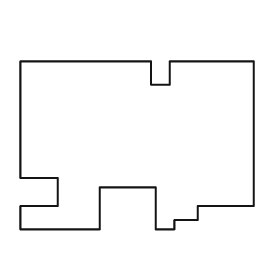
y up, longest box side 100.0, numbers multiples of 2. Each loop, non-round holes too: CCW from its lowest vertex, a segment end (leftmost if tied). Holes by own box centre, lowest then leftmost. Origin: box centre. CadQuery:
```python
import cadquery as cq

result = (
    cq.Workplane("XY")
    .moveTo(-50.0, -36.0)
    .lineTo(-16.0, -36.0)
    .lineTo(-16.0, -18.0)
    .lineTo(8.0, -18.0)
    .lineTo(8.0, -36.0)
    .lineTo(16.0, -36.0)
    .lineTo(16.0, -32.0)
    .lineTo(26.0, -32.0)
    .lineTo(26.0, -26.0)
    .lineTo(50.0, -26.0)
    .lineTo(50.0, 36.0)
    .lineTo(14.0, 36.0)
    .lineTo(14.0, 26.0)
    .lineTo(6.0, 26.0)
    .lineTo(6.0, 36.0)
    .lineTo(-50.0, 36.0)
    .lineTo(-50.0, -14.0)
    .lineTo(-34.0, -14.0)
    .lineTo(-34.0, -26.0)
    .lineTo(-50.0, -26.0)
    .close()
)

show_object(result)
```